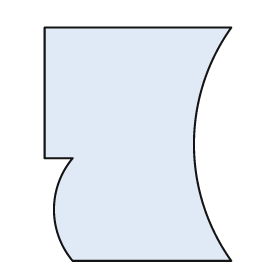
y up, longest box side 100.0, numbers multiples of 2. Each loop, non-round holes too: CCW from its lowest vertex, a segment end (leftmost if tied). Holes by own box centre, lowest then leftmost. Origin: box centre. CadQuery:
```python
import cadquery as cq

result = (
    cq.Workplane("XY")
    .moveTo(-28.0, -50.0)
    .lineTo(40.0, -50.0)
    .threePointArc((24.0, 0.0), (40.0, 50.0))
    .lineTo(-40.0, 50.0)
    .lineTo(-40.0, -6.0)
    .lineTo(-28.0, -6.0)
    .threePointArc((-36.0, -28.0), (-28.0, -50.0))
    .close()
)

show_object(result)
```